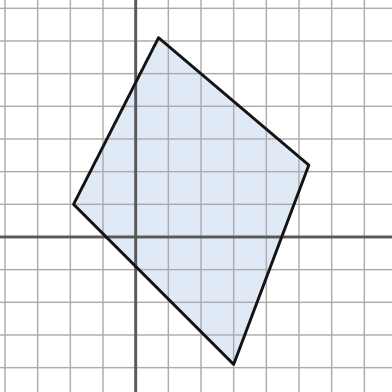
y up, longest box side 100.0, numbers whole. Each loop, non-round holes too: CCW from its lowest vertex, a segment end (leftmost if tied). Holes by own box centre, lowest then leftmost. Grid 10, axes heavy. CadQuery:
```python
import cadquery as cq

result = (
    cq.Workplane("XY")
    .moveTo(30.0, -39.0)
    .lineTo(53.0, 22.0)
    .lineTo(7.0, 61.0)
    .lineTo(-19.0, 10.0)
    .close()
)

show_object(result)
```